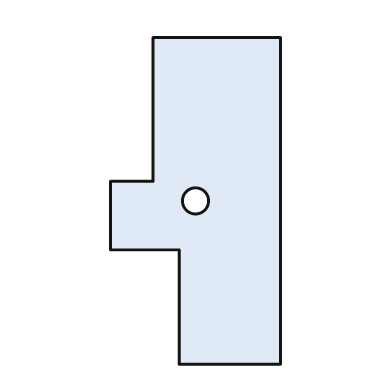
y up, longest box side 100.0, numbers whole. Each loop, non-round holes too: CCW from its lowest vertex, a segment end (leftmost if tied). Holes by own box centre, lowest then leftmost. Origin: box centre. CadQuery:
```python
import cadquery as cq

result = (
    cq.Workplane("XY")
    .moveTo(-5.0, -50.0)
    .lineTo(26.0, -50.0)
    .lineTo(26.0, 50.0)
    .lineTo(-13.0, 50.0)
    .lineTo(-13.0, 6.0)
    .lineTo(-26.0, 6.0)
    .lineTo(-26.0, -15.0)
    .lineTo(-5.0, -15.0)
    .close()
    .moveTo(0.0, 0.0)
    .circle(4.0)
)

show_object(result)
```